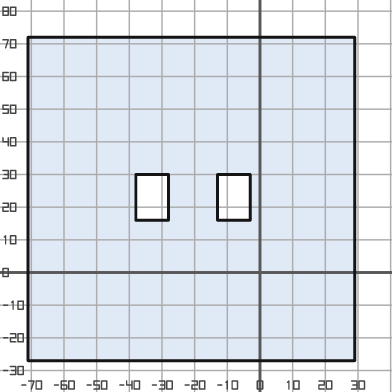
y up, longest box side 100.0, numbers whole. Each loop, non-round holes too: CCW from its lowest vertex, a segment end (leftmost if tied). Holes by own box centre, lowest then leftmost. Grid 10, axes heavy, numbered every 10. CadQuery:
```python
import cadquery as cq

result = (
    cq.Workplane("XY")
    .moveTo(-71.0, -27.0)
    .lineTo(29.0, -27.0)
    .lineTo(29.0, 72.0)
    .lineTo(-71.0, 72.0)
    .close()
    .moveTo(-38.0, 16.0)
    .lineTo(-28.0, 16.0)
    .lineTo(-28.0, 30.0)
    .lineTo(-38.0, 30.0)
    .close()
    .moveTo(-13.0, 16.0)
    .lineTo(-3.0, 16.0)
    .lineTo(-3.0, 30.0)
    .lineTo(-13.0, 30.0)
    .close()
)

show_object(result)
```